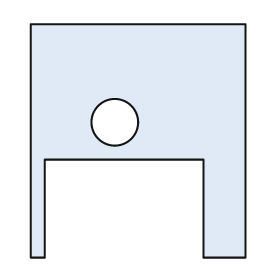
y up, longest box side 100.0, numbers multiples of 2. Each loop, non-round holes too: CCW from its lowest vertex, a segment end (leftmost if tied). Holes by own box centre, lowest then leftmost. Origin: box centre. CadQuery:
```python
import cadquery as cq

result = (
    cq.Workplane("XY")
    .moveTo(-46.0, -50.0)
    .lineTo(-40.0, -50.0)
    .lineTo(-40.0, -8.0)
    .lineTo(28.0, -8.0)
    .lineTo(28.0, -50.0)
    .lineTo(46.0, -50.0)
    .lineTo(46.0, 50.0)
    .lineTo(-46.0, 50.0)
    .close()
    .moveTo(-10.0, 8.0)
    .circle(10.0)
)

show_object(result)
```